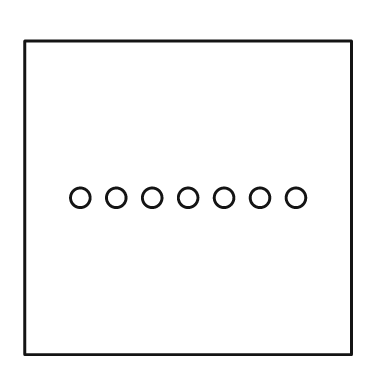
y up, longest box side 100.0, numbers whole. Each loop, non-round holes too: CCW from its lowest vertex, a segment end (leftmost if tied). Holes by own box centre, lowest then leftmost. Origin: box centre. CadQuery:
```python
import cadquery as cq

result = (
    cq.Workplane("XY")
    .moveTo(-50.0, -48.0)
    .lineTo(50.0, -48.0)
    .lineTo(50.0, 48.0)
    .lineTo(-50.0, 48.0)
    .close()
    .moveTo(-33.0, 0.0)
    .circle(3.0)
    .moveTo(-22.0, 0.0)
    .circle(3.0)
    .moveTo(-11.0, 0.0)
    .circle(3.0)
    .moveTo(0.0, 0.0)
    .circle(3.0)
    .moveTo(11.0, 0.0)
    .circle(3.0)
    .moveTo(22.0, 0.0)
    .circle(3.0)
    .moveTo(33.0, 0.0)
    .circle(3.0)
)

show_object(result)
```